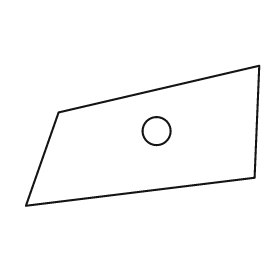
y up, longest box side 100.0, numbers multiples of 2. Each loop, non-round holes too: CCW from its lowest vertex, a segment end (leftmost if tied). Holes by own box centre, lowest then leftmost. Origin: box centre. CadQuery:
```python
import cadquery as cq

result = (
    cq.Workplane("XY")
    .moveTo(-50.0, -30.0)
    .lineTo(48.0, -18.0)
    .lineTo(50.0, 30.0)
    .lineTo(-36.0, 10.0)
    .close()
    .moveTo(6.0, 2.0)
    .circle(6.0)
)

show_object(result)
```